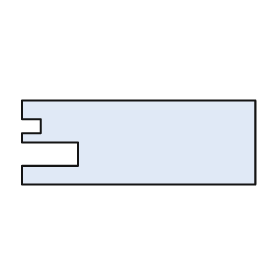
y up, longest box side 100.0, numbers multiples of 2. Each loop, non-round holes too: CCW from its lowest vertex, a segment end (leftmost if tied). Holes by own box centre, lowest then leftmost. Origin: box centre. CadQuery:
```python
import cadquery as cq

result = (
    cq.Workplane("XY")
    .moveTo(-50.0, -18.0)
    .lineTo(50.0, -18.0)
    .lineTo(50.0, 18.0)
    .lineTo(-50.0, 18.0)
    .lineTo(-50.0, 10.0)
    .lineTo(-42.0, 10.0)
    .lineTo(-42.0, 4.0)
    .lineTo(-50.0, 4.0)
    .lineTo(-50.0, 0.0)
    .lineTo(-26.0, 0.0)
    .lineTo(-26.0, -10.0)
    .lineTo(-50.0, -10.0)
    .close()
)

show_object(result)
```